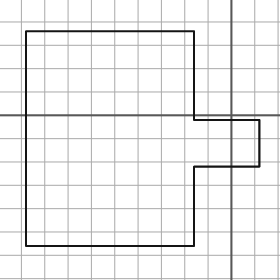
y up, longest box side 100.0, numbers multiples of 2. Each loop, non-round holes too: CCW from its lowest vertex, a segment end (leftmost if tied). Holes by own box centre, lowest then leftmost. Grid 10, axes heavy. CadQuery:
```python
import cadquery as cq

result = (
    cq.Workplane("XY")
    .moveTo(-88.0, -56.0)
    .lineTo(-16.0, -56.0)
    .lineTo(-16.0, -22.0)
    .lineTo(12.0, -22.0)
    .lineTo(12.0, -2.0)
    .lineTo(-16.0, -2.0)
    .lineTo(-16.0, 36.0)
    .lineTo(-88.0, 36.0)
    .close()
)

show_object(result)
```